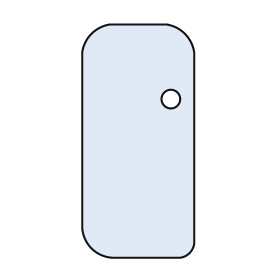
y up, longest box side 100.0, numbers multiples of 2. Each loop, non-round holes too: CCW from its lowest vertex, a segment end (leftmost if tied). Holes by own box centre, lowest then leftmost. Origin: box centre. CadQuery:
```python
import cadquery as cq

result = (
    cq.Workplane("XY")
    .moveTo(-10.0, -50.0)
    .lineTo(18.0, -50.0)
    .threePointArc((22.0, -48.0), (24.0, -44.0))
    .lineTo(24.0, 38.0)
    .threePointArc((20.0, 46.0), (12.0, 50.0))
    .lineTo(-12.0, 50.0)
    .threePointArc((-20.0, 46.0), (-24.0, 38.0))
    .lineTo(-24.0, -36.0)
    .threePointArc((-20.0, -46.0), (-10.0, -50.0))
    .close()
    .moveTo(14.0, 18.0)
    .circle(4.0)
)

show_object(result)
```